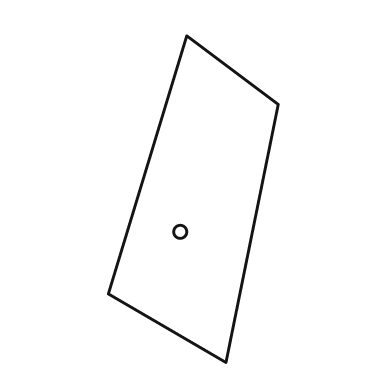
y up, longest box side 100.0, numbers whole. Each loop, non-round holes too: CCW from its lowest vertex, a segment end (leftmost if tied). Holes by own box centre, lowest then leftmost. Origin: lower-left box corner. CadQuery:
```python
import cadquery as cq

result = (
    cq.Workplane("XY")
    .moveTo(36.0, 0.0)
    .lineTo(52.0, 79.0)
    .lineTo(24.0, 100.0)
    .lineTo(0.0, 21.0)
    .close()
    .moveTo(22.0, 40.0)
    .circle(2.0)
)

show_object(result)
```